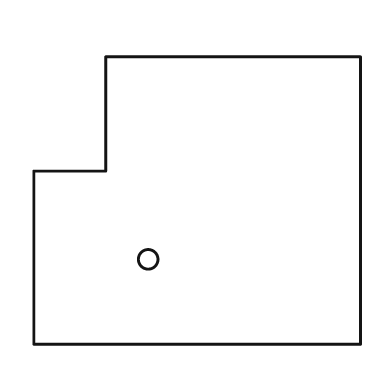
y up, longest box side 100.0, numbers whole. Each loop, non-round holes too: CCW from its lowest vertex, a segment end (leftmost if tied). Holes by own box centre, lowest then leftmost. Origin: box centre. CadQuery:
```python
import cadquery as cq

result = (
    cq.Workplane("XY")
    .moveTo(-50.0, -44.0)
    .lineTo(50.0, -44.0)
    .lineTo(50.0, 44.0)
    .lineTo(-28.0, 44.0)
    .lineTo(-28.0, 9.0)
    .lineTo(-50.0, 9.0)
    .close()
    .moveTo(-15.0, -18.0)
    .circle(3.0)
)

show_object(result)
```